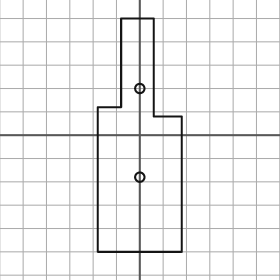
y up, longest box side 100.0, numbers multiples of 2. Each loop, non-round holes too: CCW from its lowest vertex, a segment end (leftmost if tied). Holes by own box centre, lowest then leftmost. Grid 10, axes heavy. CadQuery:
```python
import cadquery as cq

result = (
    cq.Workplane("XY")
    .moveTo(-18.0, -50.0)
    .lineTo(18.0, -50.0)
    .lineTo(18.0, 8.0)
    .lineTo(6.0, 8.0)
    .lineTo(6.0, 50.0)
    .lineTo(-8.0, 50.0)
    .lineTo(-8.0, 12.0)
    .lineTo(-18.0, 12.0)
    .close()
    .moveTo(0.0, -18.0)
    .circle(2.0)
    .moveTo(0.0, 20.0)
    .circle(2.0)
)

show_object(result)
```